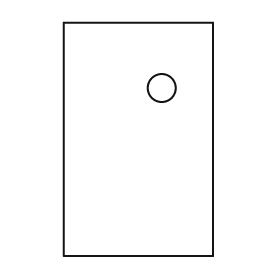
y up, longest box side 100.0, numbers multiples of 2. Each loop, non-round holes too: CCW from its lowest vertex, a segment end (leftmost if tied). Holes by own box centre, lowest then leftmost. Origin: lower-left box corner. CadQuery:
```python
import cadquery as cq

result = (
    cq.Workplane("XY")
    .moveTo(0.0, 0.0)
    .lineTo(64.0, 0.0)
    .lineTo(64.0, 100.0)
    .lineTo(0.0, 100.0)
    .close()
    .moveTo(42.0, 72.0)
    .circle(6.0)
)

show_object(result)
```